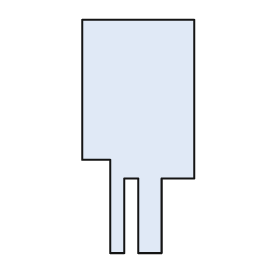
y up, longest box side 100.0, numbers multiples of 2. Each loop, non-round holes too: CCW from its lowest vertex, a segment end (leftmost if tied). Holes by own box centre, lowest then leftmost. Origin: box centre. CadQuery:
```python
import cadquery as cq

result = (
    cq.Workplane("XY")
    .moveTo(-12.0, -50.0)
    .lineTo(-6.0, -50.0)
    .lineTo(-6.0, -18.0)
    .lineTo(0.0, -18.0)
    .lineTo(0.0, -50.0)
    .lineTo(10.0, -50.0)
    .lineTo(10.0, -18.0)
    .lineTo(24.0, -18.0)
    .lineTo(24.0, 50.0)
    .lineTo(-24.0, 50.0)
    .lineTo(-24.0, -10.0)
    .lineTo(-12.0, -10.0)
    .close()
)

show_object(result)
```